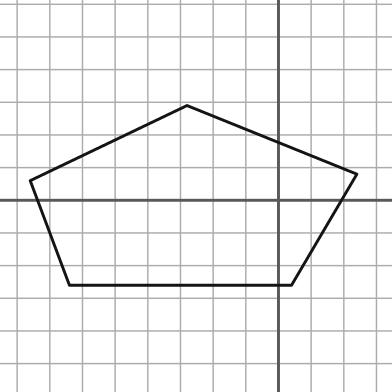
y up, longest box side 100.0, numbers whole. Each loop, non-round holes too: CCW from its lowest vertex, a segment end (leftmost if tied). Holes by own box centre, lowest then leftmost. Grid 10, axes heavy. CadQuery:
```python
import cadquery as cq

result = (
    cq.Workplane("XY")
    .moveTo(-64.0, -26.0)
    .lineTo(4.0, -26.0)
    .lineTo(24.0, 8.0)
    .lineTo(-28.0, 29.0)
    .lineTo(-76.0, 6.0)
    .close()
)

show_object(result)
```